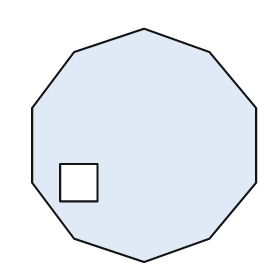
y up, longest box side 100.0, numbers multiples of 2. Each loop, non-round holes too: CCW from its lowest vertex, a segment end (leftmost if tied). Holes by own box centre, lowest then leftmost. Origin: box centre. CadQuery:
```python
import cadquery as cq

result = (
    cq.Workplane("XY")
    .moveTo(0.0, -50.0)
    .lineTo(28.0, -40.0)
    .lineTo(48.0, -16.0)
    .lineTo(48.0, 16.0)
    .lineTo(28.0, 40.0)
    .lineTo(0.0, 50.0)
    .lineTo(-30.0, 40.0)
    .lineTo(-48.0, 16.0)
    .lineTo(-48.0, -16.0)
    .lineTo(-30.0, -40.0)
    .close()
    .moveTo(-36.0, -24.0)
    .lineTo(-20.0, -24.0)
    .lineTo(-20.0, -8.0)
    .lineTo(-36.0, -8.0)
    .close()
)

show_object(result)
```